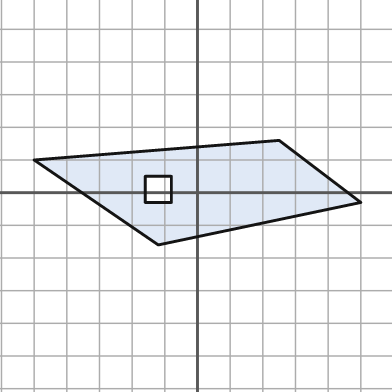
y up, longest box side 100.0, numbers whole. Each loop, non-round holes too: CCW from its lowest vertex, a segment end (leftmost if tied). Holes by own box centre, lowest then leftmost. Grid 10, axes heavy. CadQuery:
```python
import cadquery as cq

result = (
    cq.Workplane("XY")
    .moveTo(-12.0, -16.0)
    .lineTo(50.0, -3.0)
    .lineTo(25.0, 16.0)
    .lineTo(-50.0, 10.0)
    .close()
    .moveTo(-16.0, -3.0)
    .lineTo(-8.0, -3.0)
    .lineTo(-8.0, 5.0)
    .lineTo(-16.0, 5.0)
    .close()
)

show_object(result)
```